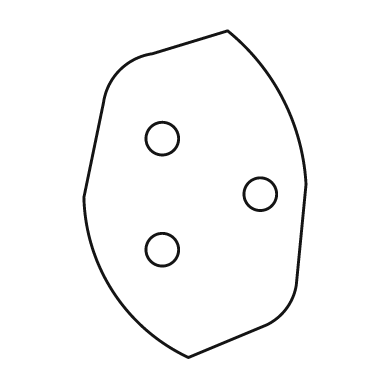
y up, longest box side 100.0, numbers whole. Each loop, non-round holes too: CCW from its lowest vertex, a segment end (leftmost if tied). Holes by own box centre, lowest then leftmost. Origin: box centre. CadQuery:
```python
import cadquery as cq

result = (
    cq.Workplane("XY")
    .moveTo(-2.0, -50.0)
    .lineTo(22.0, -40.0)
    .threePointArc((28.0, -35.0), (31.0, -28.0))
    .lineTo(34.0, 3.0)
    .threePointArc((27.0, 29.0), (10.0, 50.0))
    .lineTo(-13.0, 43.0)
    .threePointArc((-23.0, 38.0), (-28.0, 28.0))
    .lineTo(-34.0, -1.0)
    .threePointArc((-25.0, -30.0), (-2.0, -50.0))
    .close()
    .moveTo(-10.0, -17.0)
    .circle(5.0)
    .moveTo(20.0, 0.0)
    .circle(5.0)
    .moveTo(-10.0, 17.0)
    .circle(5.0)
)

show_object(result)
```